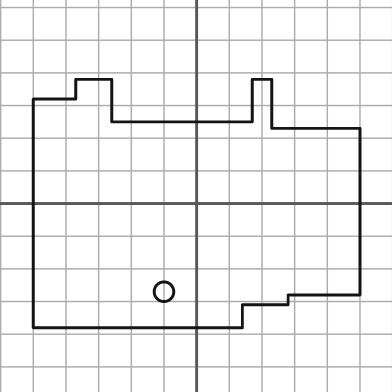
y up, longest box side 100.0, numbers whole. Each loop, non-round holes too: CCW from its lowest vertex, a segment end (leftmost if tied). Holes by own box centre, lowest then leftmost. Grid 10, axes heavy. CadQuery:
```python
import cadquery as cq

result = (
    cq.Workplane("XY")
    .moveTo(-50.0, -38.0)
    .lineTo(14.0, -38.0)
    .lineTo(14.0, -31.0)
    .lineTo(28.0, -31.0)
    .lineTo(28.0, -28.0)
    .lineTo(50.0, -28.0)
    .lineTo(50.0, 23.0)
    .lineTo(23.0, 23.0)
    .lineTo(23.0, 38.0)
    .lineTo(17.0, 38.0)
    .lineTo(17.0, 25.0)
    .lineTo(-26.0, 25.0)
    .lineTo(-26.0, 38.0)
    .lineTo(-37.0, 38.0)
    .lineTo(-37.0, 32.0)
    .lineTo(-50.0, 32.0)
    .close()
    .moveTo(-10.0, -27.0)
    .circle(3.0)
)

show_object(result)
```